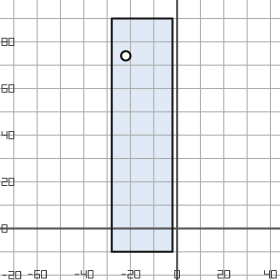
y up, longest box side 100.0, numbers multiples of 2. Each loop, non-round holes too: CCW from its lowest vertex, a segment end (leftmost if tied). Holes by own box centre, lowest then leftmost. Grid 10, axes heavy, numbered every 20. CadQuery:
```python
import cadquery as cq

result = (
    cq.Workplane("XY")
    .moveTo(-28.0, -10.0)
    .lineTo(-2.0, -10.0)
    .lineTo(-2.0, 90.0)
    .lineTo(-28.0, 90.0)
    .close()
    .moveTo(-22.0, 74.0)
    .circle(2.0)
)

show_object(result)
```